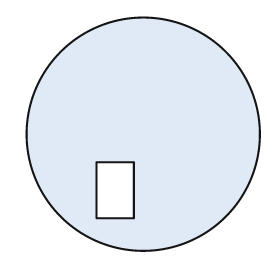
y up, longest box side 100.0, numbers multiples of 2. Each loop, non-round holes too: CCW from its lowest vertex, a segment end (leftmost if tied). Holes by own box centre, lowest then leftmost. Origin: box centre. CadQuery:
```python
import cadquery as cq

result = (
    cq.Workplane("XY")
    .moveTo(0.0, 0.0)
    .circle(50.0)
    .moveTo(-20.0, -36.0)
    .lineTo(-4.0, -36.0)
    .lineTo(-4.0, -12.0)
    .lineTo(-20.0, -12.0)
    .close()
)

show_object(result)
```